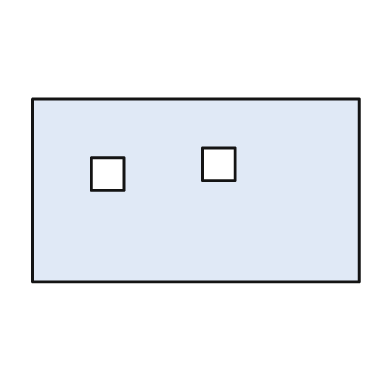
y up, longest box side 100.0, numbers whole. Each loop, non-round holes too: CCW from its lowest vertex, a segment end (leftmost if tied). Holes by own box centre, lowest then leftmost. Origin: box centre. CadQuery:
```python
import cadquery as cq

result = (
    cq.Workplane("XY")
    .moveTo(-50.0, -28.0)
    .lineTo(50.0, -28.0)
    .lineTo(50.0, 28.0)
    .lineTo(-50.0, 28.0)
    .close()
    .moveTo(-32.0, 0.0)
    .lineTo(-22.0, 0.0)
    .lineTo(-22.0, 10.0)
    .lineTo(-32.0, 10.0)
    .close()
    .moveTo(2.0, 3.0)
    .lineTo(12.0, 3.0)
    .lineTo(12.0, 13.0)
    .lineTo(2.0, 13.0)
    .close()
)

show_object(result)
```